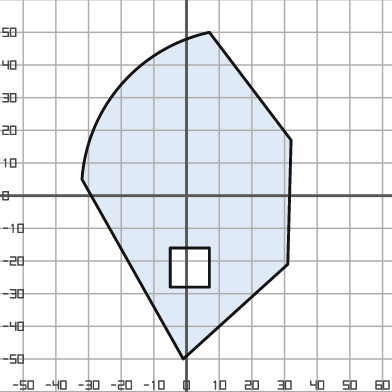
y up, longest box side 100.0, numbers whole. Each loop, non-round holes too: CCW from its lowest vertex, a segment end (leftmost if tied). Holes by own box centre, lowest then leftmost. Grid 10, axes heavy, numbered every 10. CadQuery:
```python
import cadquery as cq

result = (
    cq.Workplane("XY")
    .moveTo(-1.0, -50.0)
    .lineTo(31.0, -21.0)
    .lineTo(32.0, 17.0)
    .lineTo(7.0, 50.0)
    .threePointArc((-20.0, 34.0), (-32.0, 5.0))
    .close()
    .moveTo(-5.0, -28.0)
    .lineTo(7.0, -28.0)
    .lineTo(7.0, -16.0)
    .lineTo(-5.0, -16.0)
    .close()
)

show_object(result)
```